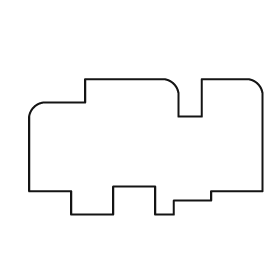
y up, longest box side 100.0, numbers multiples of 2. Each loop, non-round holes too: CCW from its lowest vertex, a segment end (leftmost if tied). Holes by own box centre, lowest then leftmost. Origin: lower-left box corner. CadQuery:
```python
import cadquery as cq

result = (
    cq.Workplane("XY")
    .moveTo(18.0, 0.0)
    .lineTo(36.0, 0.0)
    .lineTo(36.0, 12.0)
    .lineTo(54.0, 12.0)
    .lineTo(54.0, 0.0)
    .lineTo(62.0, 0.0)
    .lineTo(62.0, 6.0)
    .lineTo(78.0, 6.0)
    .lineTo(78.0, 10.0)
    .lineTo(100.0, 10.0)
    .lineTo(100.0, 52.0)
    .threePointArc((98.0, 56.0), (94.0, 58.0))
    .lineTo(74.0, 58.0)
    .lineTo(74.0, 42.0)
    .lineTo(64.0, 42.0)
    .lineTo(64.0, 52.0)
    .threePointArc((62.0, 56.0), (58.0, 58.0))
    .lineTo(24.0, 58.0)
    .lineTo(24.0, 48.0)
    .lineTo(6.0, 48.0)
    .threePointArc((2.0, 46.0), (0.0, 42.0))
    .lineTo(0.0, 10.0)
    .lineTo(18.0, 10.0)
    .close()
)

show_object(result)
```